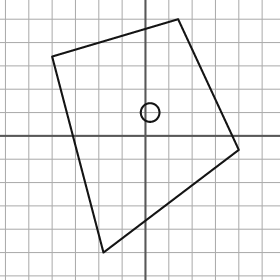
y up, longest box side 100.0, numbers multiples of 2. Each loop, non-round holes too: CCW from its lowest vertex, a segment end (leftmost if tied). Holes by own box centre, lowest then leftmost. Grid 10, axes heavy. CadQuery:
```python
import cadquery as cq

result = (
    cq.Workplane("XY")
    .moveTo(-18.0, -50.0)
    .lineTo(40.0, -6.0)
    .lineTo(14.0, 50.0)
    .lineTo(-40.0, 34.0)
    .close()
    .moveTo(2.0, 10.0)
    .circle(4.0)
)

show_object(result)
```